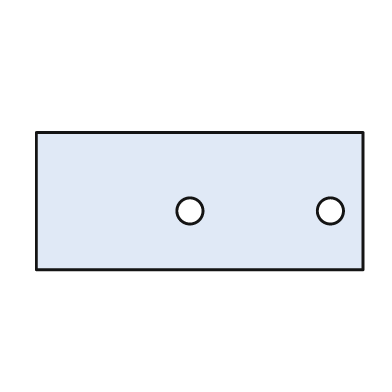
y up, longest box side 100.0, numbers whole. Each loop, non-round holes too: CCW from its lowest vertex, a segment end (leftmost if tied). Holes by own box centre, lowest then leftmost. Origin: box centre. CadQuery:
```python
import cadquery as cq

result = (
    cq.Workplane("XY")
    .moveTo(-50.0, -21.0)
    .lineTo(50.0, -21.0)
    .lineTo(50.0, 21.0)
    .lineTo(-50.0, 21.0)
    .close()
    .moveTo(-3.0, -3.0)
    .circle(4.0)
    .moveTo(40.0, -3.0)
    .circle(4.0)
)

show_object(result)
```